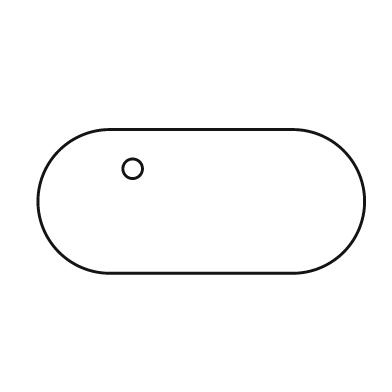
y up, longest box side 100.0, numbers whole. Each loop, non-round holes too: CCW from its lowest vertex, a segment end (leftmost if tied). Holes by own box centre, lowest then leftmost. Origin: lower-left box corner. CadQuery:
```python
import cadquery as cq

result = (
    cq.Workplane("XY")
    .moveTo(22.0, 0.0)
    .lineTo(78.0, 0.0)
    .threePointArc((100.0, 22.0), (78.0, 44.0))
    .lineTo(22.0, 44.0)
    .threePointArc((0.0, 22.0), (22.0, 0.0))
    .close()
    .moveTo(29.0, 32.0)
    .circle(3.0)
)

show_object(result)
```